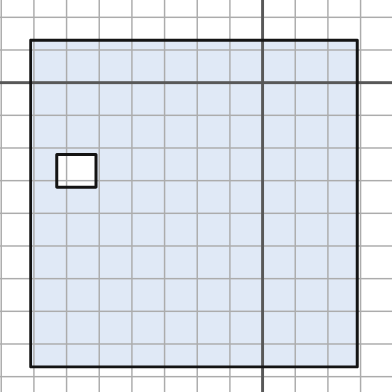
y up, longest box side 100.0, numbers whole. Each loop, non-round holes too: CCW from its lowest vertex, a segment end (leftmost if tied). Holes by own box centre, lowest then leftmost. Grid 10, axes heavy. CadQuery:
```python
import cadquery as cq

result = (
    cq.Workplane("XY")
    .moveTo(-71.0, -87.0)
    .lineTo(29.0, -87.0)
    .lineTo(29.0, 13.0)
    .lineTo(-71.0, 13.0)
    .close()
    .moveTo(-63.0, -32.0)
    .lineTo(-51.0, -32.0)
    .lineTo(-51.0, -22.0)
    .lineTo(-63.0, -22.0)
    .close()
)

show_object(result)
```